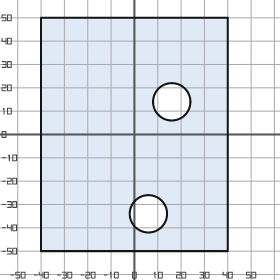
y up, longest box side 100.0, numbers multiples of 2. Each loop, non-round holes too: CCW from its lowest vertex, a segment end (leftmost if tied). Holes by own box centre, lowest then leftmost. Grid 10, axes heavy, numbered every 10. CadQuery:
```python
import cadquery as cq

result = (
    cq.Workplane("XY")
    .moveTo(-40.0, -50.0)
    .lineTo(40.0, -50.0)
    .lineTo(40.0, 50.0)
    .lineTo(-40.0, 50.0)
    .close()
    .moveTo(6.0, -34.0)
    .circle(8.0)
    .moveTo(16.0, 14.0)
    .circle(8.0)
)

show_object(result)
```